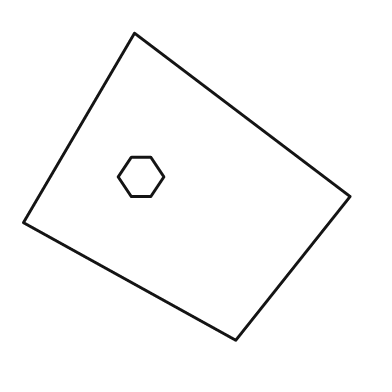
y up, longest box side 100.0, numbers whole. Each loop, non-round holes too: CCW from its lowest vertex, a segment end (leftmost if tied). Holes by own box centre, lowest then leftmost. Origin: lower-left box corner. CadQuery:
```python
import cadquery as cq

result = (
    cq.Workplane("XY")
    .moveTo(65.0, 0.0)
    .lineTo(100.0, 44.0)
    .lineTo(34.0, 94.0)
    .lineTo(0.0, 36.0)
    .close()
    .moveTo(33.0, 44.0)
    .lineTo(39.0, 44.0)
    .lineTo(43.0, 50.0)
    .lineTo(39.0, 56.0)
    .lineTo(33.0, 56.0)
    .lineTo(29.0, 50.0)
    .close()
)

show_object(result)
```